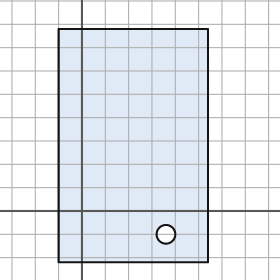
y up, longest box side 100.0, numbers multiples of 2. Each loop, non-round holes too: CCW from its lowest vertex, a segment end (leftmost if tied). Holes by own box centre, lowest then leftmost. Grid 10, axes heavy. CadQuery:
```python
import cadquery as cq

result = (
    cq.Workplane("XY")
    .moveTo(-10.0, -22.0)
    .lineTo(54.0, -22.0)
    .lineTo(54.0, 78.0)
    .lineTo(-10.0, 78.0)
    .close()
    .moveTo(36.0, -10.0)
    .circle(4.0)
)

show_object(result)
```